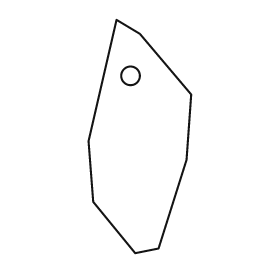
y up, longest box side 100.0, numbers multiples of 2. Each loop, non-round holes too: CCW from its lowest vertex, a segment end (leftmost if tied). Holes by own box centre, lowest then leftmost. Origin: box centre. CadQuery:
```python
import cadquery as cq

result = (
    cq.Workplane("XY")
    .moveTo(-2.0, -50.0)
    .lineTo(8.0, -48.0)
    .lineTo(20.0, -10.0)
    .lineTo(22.0, 18.0)
    .lineTo(0.0, 44.0)
    .lineTo(-10.0, 50.0)
    .lineTo(-22.0, -2.0)
    .lineTo(-20.0, -28.0)
    .close()
    .moveTo(-4.0, 26.0)
    .circle(4.0)
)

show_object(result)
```